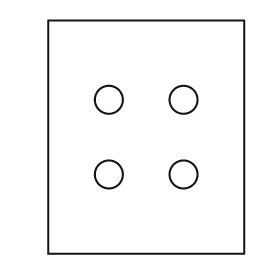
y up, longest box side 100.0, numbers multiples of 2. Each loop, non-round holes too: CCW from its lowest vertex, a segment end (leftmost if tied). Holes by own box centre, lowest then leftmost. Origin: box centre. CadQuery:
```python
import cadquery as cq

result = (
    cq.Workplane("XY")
    .moveTo(-42.0, -50.0)
    .lineTo(42.0, -50.0)
    .lineTo(42.0, 50.0)
    .lineTo(-42.0, 50.0)
    .close()
    .moveTo(-16.0, -16.0)
    .circle(6.0)
    .moveTo(16.0, -16.0)
    .circle(6.0)
    .moveTo(-16.0, 16.0)
    .circle(6.0)
    .moveTo(16.0, 16.0)
    .circle(6.0)
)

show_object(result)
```